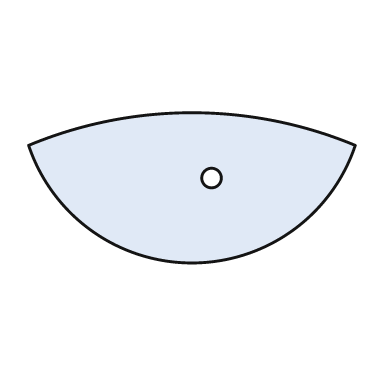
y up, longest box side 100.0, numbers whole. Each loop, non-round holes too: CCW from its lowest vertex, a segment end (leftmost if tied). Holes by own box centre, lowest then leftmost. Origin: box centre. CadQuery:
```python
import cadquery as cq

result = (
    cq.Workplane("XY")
    .moveTo(-50.0, 13.0)
    .threePointArc((0.0, -23.0), (50.0, 13.0))
    .threePointArc((0.0, 23.0), (-50.0, 13.0))
    .close()
    .moveTo(6.0, 3.0)
    .circle(3.0)
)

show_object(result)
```